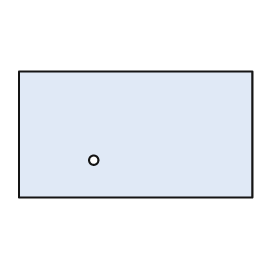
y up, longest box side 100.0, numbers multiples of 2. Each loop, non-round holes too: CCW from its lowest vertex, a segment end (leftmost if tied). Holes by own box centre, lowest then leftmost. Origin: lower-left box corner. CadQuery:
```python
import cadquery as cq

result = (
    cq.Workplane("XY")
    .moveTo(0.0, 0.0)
    .lineTo(100.0, 0.0)
    .lineTo(100.0, 54.0)
    .lineTo(0.0, 54.0)
    .close()
    .moveTo(32.0, 16.0)
    .circle(2.0)
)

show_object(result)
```